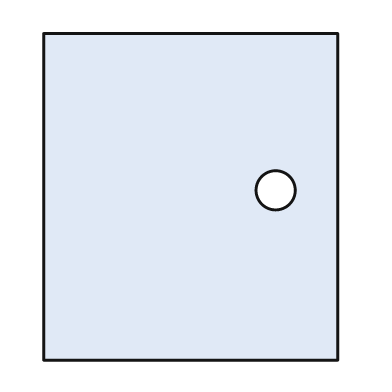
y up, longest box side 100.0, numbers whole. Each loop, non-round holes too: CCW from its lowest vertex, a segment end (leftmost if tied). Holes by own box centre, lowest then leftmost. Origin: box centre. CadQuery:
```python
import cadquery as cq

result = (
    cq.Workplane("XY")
    .moveTo(-45.0, -50.0)
    .lineTo(45.0, -50.0)
    .lineTo(45.0, 50.0)
    .lineTo(-45.0, 50.0)
    .close()
    .moveTo(26.0, 2.0)
    .circle(6.0)
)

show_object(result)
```